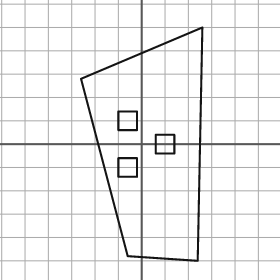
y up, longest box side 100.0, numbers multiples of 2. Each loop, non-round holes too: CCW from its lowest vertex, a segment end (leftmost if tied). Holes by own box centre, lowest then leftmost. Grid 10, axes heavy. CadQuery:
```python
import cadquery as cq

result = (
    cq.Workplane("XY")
    .moveTo(24.0, -50.0)
    .lineTo(26.0, 50.0)
    .lineTo(-26.0, 28.0)
    .lineTo(-6.0, -48.0)
    .close()
    .moveTo(-10.0, -14.0)
    .lineTo(-2.0, -14.0)
    .lineTo(-2.0, -6.0)
    .lineTo(-10.0, -6.0)
    .close()
    .moveTo(6.0, -4.0)
    .lineTo(14.0, -4.0)
    .lineTo(14.0, 4.0)
    .lineTo(6.0, 4.0)
    .close()
    .moveTo(-10.0, 6.0)
    .lineTo(-2.0, 6.0)
    .lineTo(-2.0, 14.0)
    .lineTo(-10.0, 14.0)
    .close()
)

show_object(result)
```